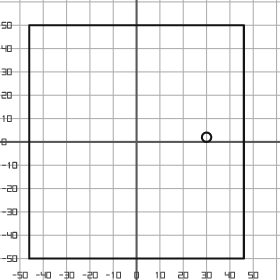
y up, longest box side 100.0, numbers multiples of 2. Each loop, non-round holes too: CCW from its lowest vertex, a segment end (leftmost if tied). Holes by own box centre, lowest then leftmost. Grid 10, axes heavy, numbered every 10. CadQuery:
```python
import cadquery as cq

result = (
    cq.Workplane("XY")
    .moveTo(-46.0, -50.0)
    .lineTo(46.0, -50.0)
    .lineTo(46.0, 50.0)
    .lineTo(-46.0, 50.0)
    .close()
    .moveTo(30.0, 2.0)
    .circle(2.0)
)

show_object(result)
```